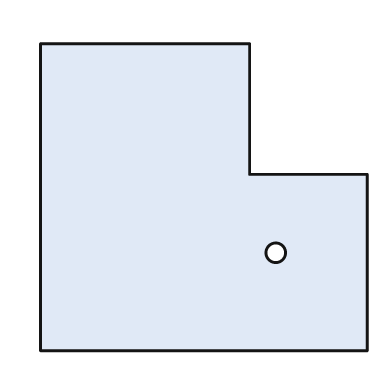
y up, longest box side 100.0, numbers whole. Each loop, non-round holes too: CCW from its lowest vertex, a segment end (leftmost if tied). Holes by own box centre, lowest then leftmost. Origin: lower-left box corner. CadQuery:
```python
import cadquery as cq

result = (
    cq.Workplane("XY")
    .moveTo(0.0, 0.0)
    .lineTo(100.0, 0.0)
    .lineTo(100.0, 54.0)
    .lineTo(64.0, 54.0)
    .lineTo(64.0, 94.0)
    .lineTo(0.0, 94.0)
    .close()
    .moveTo(72.0, 30.0)
    .circle(3.0)
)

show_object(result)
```